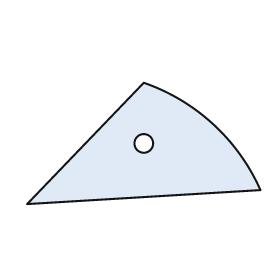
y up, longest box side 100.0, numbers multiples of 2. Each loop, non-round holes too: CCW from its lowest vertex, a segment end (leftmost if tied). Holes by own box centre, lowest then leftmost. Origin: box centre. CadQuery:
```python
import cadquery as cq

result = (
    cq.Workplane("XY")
    .moveTo(-50.0, -26.0)
    .lineTo(50.0, -20.0)
    .threePointArc((30.0, 8.0), (0.0, 26.0))
    .close()
    .moveTo(0.0, 0.0)
    .circle(4.0)
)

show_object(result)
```